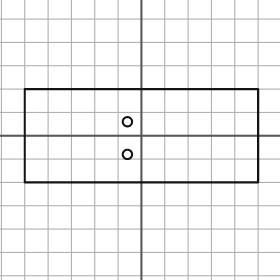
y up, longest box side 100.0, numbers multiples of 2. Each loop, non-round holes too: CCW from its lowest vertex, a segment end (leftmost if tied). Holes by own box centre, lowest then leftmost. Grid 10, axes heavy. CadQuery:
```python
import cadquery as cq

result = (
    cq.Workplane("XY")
    .moveTo(-50.0, -20.0)
    .lineTo(50.0, -20.0)
    .lineTo(50.0, 20.0)
    .lineTo(-50.0, 20.0)
    .close()
    .moveTo(-6.0, -8.0)
    .circle(2.0)
    .moveTo(-6.0, 6.0)
    .circle(2.0)
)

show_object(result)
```